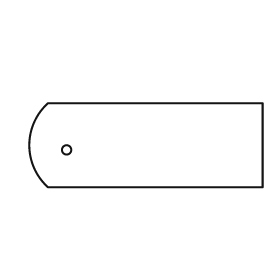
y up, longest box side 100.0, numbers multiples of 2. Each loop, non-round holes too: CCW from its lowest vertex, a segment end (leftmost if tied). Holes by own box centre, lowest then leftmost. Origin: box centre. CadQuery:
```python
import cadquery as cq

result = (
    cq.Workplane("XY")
    .moveTo(-42.0, -18.0)
    .lineTo(50.0, -18.0)
    .lineTo(50.0, 18.0)
    .lineTo(-42.0, 18.0)
    .threePointArc((-50.0, 0.0), (-42.0, -18.0))
    .close()
    .moveTo(-34.0, -2.0)
    .circle(2.0)
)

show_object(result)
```